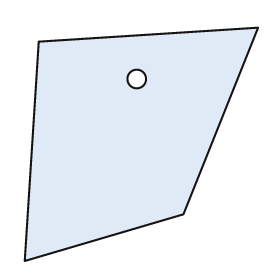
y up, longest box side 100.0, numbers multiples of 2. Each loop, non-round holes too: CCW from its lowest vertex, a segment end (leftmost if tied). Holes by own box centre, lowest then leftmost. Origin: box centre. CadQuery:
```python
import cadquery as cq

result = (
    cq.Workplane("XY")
    .moveTo(-50.0, -50.0)
    .lineTo(18.0, -30.0)
    .lineTo(50.0, 50.0)
    .lineTo(-44.0, 44.0)
    .close()
    .moveTo(-2.0, 28.0)
    .circle(4.0)
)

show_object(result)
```